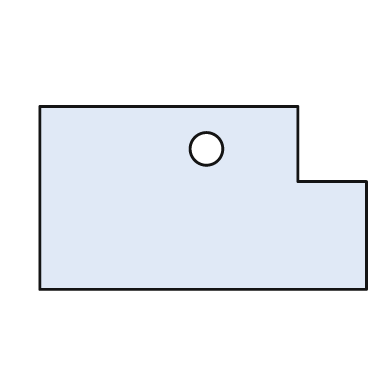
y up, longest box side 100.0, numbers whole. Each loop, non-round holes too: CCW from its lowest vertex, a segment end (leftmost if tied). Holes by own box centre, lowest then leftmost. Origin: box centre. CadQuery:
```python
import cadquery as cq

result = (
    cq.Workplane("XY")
    .moveTo(-50.0, -28.0)
    .lineTo(50.0, -28.0)
    .lineTo(50.0, 5.0)
    .lineTo(29.0, 5.0)
    .lineTo(29.0, 28.0)
    .lineTo(-50.0, 28.0)
    .close()
    .moveTo(1.0, 15.0)
    .circle(5.0)
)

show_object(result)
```